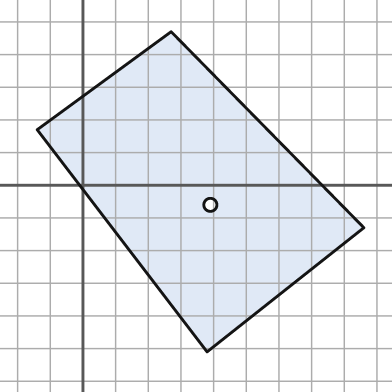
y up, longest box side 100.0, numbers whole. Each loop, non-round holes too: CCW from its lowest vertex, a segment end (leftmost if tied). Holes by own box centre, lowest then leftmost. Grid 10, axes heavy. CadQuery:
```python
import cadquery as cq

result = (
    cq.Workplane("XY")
    .moveTo(38.0, -51.0)
    .lineTo(86.0, -13.0)
    .lineTo(27.0, 47.0)
    .lineTo(-14.0, 17.0)
    .close()
    .moveTo(39.0, -6.0)
    .circle(2.0)
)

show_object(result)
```